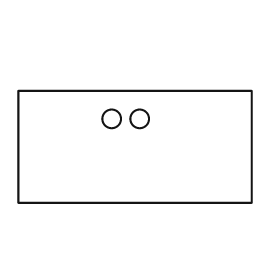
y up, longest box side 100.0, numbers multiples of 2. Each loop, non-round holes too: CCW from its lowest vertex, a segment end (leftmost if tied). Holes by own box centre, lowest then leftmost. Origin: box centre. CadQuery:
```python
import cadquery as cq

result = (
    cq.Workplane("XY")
    .moveTo(-50.0, -24.0)
    .lineTo(50.0, -24.0)
    .lineTo(50.0, 24.0)
    .lineTo(-50.0, 24.0)
    .close()
    .moveTo(-10.0, 12.0)
    .circle(4.0)
    .moveTo(2.0, 12.0)
    .circle(4.0)
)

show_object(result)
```